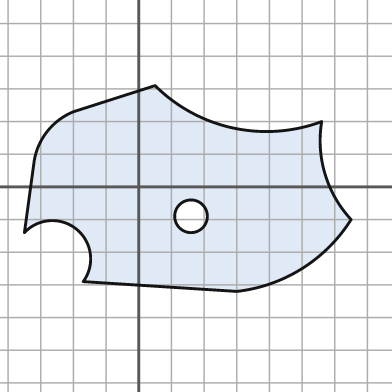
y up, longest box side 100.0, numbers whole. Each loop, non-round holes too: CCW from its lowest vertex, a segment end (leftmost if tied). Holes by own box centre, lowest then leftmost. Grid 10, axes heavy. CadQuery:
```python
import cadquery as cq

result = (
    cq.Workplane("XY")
    .moveTo(30.0, -32.0)
    .threePointArc((50.0, -25.0), (65.0, -10.0))
    .threePointArc((57.0, 4.0), (56.0, 20.0))
    .threePointArc((29.0, 18.0), (5.0, 31.0))
    .lineTo(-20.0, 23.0)
    .threePointArc((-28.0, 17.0), (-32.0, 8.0))
    .lineTo(-35.0, -14.0)
    .threePointArc((-19.0, -13.0), (-17.0, -29.0))
    .close()
    .moveTo(16.0, -9.0)
    .circle(5.0)
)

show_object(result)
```